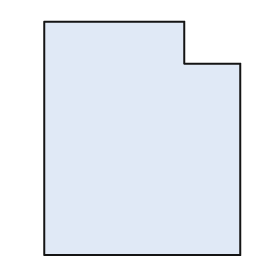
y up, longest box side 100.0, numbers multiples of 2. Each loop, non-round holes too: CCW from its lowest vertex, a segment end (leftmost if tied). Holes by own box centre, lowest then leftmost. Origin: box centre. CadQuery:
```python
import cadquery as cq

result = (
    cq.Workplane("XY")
    .moveTo(-42.0, -50.0)
    .lineTo(42.0, -50.0)
    .lineTo(42.0, 32.0)
    .lineTo(18.0, 32.0)
    .lineTo(18.0, 50.0)
    .lineTo(-42.0, 50.0)
    .close()
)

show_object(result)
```